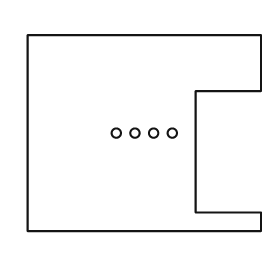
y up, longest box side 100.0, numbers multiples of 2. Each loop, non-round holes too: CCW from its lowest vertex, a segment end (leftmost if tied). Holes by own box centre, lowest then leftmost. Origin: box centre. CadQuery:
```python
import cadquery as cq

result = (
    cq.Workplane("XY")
    .moveTo(-50.0, -42.0)
    .lineTo(50.0, -42.0)
    .lineTo(50.0, -34.0)
    .lineTo(22.0, -34.0)
    .lineTo(22.0, 18.0)
    .lineTo(50.0, 18.0)
    .lineTo(50.0, 42.0)
    .lineTo(-50.0, 42.0)
    .close()
    .moveTo(-12.0, 0.0)
    .circle(2.0)
    .moveTo(-4.0, 0.0)
    .circle(2.0)
    .moveTo(4.0, 0.0)
    .circle(2.0)
    .moveTo(12.0, 0.0)
    .circle(2.0)
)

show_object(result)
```